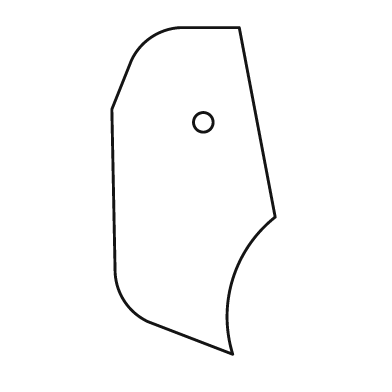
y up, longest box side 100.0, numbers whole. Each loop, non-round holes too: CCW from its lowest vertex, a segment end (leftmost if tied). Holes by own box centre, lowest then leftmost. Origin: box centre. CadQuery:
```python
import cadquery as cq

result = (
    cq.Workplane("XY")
    .moveTo(12.0, -50.0)
    .threePointArc((12.0, -27.0), (25.0, -8.0))
    .lineTo(14.0, 50.0)
    .lineTo(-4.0, 50.0)
    .threePointArc((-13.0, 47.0), (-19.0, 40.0))
    .lineTo(-25.0, 25.0)
    .lineTo(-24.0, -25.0)
    .threePointArc((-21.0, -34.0), (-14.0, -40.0))
    .close()
    .moveTo(3.0, 21.0)
    .circle(3.0)
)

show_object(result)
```